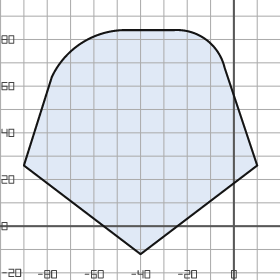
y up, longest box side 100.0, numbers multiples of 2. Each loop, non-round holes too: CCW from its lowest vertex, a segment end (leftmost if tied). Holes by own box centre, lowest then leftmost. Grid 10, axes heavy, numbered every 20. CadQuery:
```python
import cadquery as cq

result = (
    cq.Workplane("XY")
    .moveTo(-40.0, -12.0)
    .lineTo(10.0, 26.0)
    .lineTo(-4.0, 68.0)
    .threePointArc((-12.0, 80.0), (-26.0, 84.0))
    .lineTo(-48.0, 84.0)
    .threePointArc((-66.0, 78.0), (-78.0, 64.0))
    .lineTo(-90.0, 26.0)
    .close()
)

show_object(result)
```